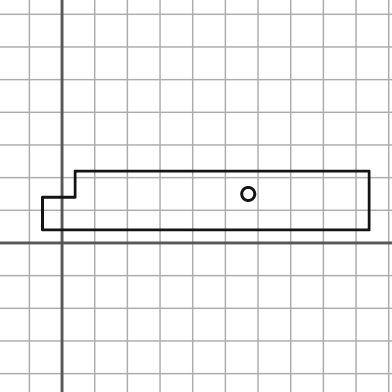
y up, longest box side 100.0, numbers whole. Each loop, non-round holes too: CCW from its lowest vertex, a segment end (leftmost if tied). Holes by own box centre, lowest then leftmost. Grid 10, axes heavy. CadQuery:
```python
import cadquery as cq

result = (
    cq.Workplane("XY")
    .moveTo(-6.0, 4.0)
    .lineTo(94.0, 4.0)
    .lineTo(94.0, 22.0)
    .lineTo(4.0, 22.0)
    .lineTo(4.0, 14.0)
    .lineTo(-6.0, 14.0)
    .close()
    .moveTo(57.0, 15.0)
    .circle(2.0)
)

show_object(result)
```